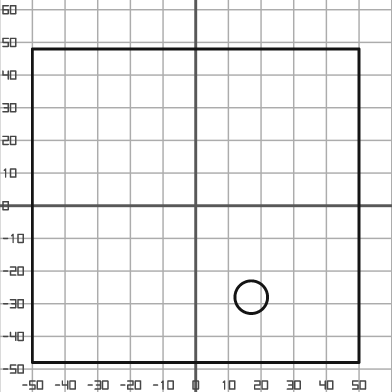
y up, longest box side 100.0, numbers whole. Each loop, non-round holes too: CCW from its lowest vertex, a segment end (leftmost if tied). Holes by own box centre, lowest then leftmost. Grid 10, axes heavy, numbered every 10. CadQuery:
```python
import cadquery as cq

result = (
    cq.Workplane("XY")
    .moveTo(-50.0, -48.0)
    .lineTo(50.0, -48.0)
    .lineTo(50.0, 48.0)
    .lineTo(-50.0, 48.0)
    .close()
    .moveTo(17.0, -28.0)
    .circle(5.0)
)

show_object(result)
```